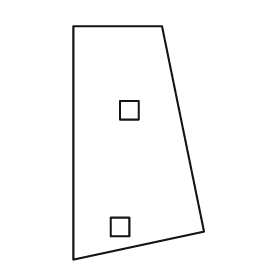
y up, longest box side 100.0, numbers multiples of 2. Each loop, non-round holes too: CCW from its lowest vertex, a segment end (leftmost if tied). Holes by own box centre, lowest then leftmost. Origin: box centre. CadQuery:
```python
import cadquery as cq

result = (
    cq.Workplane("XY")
    .moveTo(-28.0, -50.0)
    .lineTo(28.0, -38.0)
    .lineTo(10.0, 50.0)
    .lineTo(-28.0, 50.0)
    .close()
    .moveTo(-12.0, -40.0)
    .lineTo(-4.0, -40.0)
    .lineTo(-4.0, -32.0)
    .lineTo(-12.0, -32.0)
    .close()
    .moveTo(-8.0, 10.0)
    .lineTo(0.0, 10.0)
    .lineTo(0.0, 18.0)
    .lineTo(-8.0, 18.0)
    .close()
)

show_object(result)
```